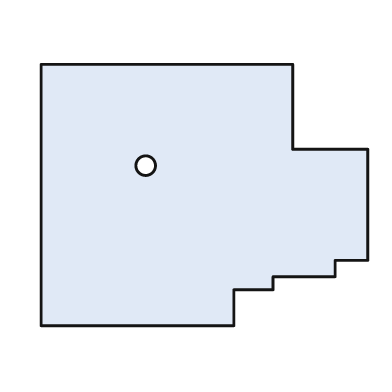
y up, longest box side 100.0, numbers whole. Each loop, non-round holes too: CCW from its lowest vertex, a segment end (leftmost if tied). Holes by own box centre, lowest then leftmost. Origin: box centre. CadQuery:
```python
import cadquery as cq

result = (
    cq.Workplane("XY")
    .moveTo(-50.0, -40.0)
    .lineTo(9.0, -40.0)
    .lineTo(9.0, -29.0)
    .lineTo(21.0, -29.0)
    .lineTo(21.0, -25.0)
    .lineTo(40.0, -25.0)
    .lineTo(40.0, -20.0)
    .lineTo(50.0, -20.0)
    .lineTo(50.0, 14.0)
    .lineTo(27.0, 14.0)
    .lineTo(27.0, 40.0)
    .lineTo(-50.0, 40.0)
    .close()
    .moveTo(-18.0, 9.0)
    .circle(3.0)
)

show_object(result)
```